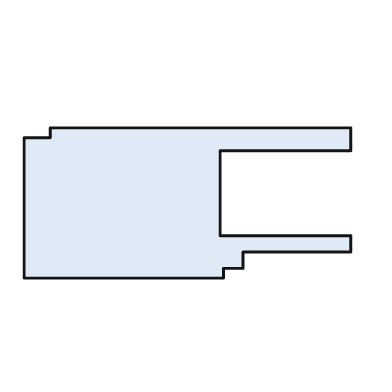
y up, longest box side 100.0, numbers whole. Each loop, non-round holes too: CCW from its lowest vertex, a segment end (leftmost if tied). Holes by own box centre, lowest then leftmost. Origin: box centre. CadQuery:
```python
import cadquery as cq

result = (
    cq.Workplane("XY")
    .moveTo(-50.0, -23.0)
    .lineTo(11.0, -23.0)
    .lineTo(11.0, -20.0)
    .lineTo(17.0, -20.0)
    .lineTo(17.0, -15.0)
    .lineTo(50.0, -15.0)
    .lineTo(50.0, -10.0)
    .lineTo(10.0, -10.0)
    .lineTo(10.0, 16.0)
    .lineTo(50.0, 16.0)
    .lineTo(50.0, 23.0)
    .lineTo(-42.0, 23.0)
    .lineTo(-42.0, 20.0)
    .lineTo(-50.0, 20.0)
    .close()
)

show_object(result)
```